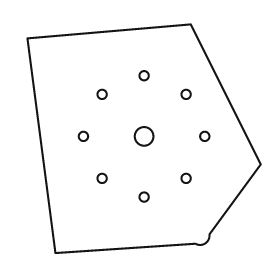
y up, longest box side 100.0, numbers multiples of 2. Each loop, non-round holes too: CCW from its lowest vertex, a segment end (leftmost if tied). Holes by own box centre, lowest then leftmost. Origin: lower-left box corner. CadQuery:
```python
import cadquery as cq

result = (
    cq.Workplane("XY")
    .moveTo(12.0, 0.0)
    .lineTo(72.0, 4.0)
    .threePointArc((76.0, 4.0), (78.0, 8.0))
    .lineTo(100.0, 38.0)
    .lineTo(70.0, 98.0)
    .lineTo(0.0, 92.0)
    .close()
    .moveTo(50.0, 24.0)
    .circle(2.0)
    .moveTo(32.0, 32.0)
    .circle(2.0)
    .moveTo(68.0, 32.0)
    .circle(2.0)
    .moveTo(24.0, 50.0)
    .circle(2.0)
    .moveTo(50.0, 50.0)
    .circle(4.0)
    .moveTo(76.0, 50.0)
    .circle(2.0)
    .moveTo(32.0, 68.0)
    .circle(2.0)
    .moveTo(68.0, 68.0)
    .circle(2.0)
    .moveTo(50.0, 76.0)
    .circle(2.0)
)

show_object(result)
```